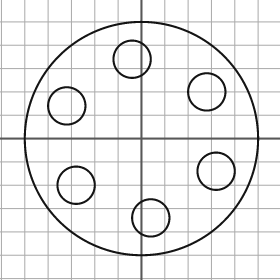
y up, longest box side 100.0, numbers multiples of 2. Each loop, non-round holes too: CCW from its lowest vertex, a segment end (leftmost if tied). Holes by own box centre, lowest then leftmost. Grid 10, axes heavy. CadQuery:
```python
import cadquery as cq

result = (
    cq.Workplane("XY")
    .moveTo(0.0, 0.0)
    .circle(50.0)
    .moveTo(4.0, -34.0)
    .circle(8.0)
    .moveTo(-28.0, -20.0)
    .circle(8.0)
    .moveTo(32.0, -14.0)
    .circle(8.0)
    .moveTo(-32.0, 14.0)
    .circle(8.0)
    .moveTo(28.0, 20.0)
    .circle(8.0)
    .moveTo(-4.0, 34.0)
    .circle(8.0)
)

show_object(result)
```